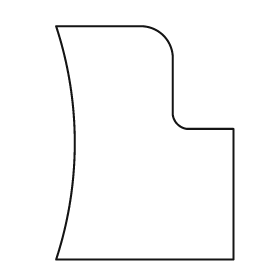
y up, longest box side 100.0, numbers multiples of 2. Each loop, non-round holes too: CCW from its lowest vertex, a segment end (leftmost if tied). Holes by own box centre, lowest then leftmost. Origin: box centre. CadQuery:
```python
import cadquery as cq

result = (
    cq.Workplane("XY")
    .moveTo(-38.0, -50.0)
    .lineTo(38.0, -50.0)
    .lineTo(38.0, 6.0)
    .lineTo(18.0, 6.0)
    .threePointArc((14.0, 8.0), (12.0, 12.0))
    .lineTo(12.0, 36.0)
    .threePointArc((8.0, 46.0), (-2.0, 50.0))
    .lineTo(-38.0, 50.0)
    .threePointArc((-30.0, 0.0), (-38.0, -50.0))
    .close()
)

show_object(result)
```